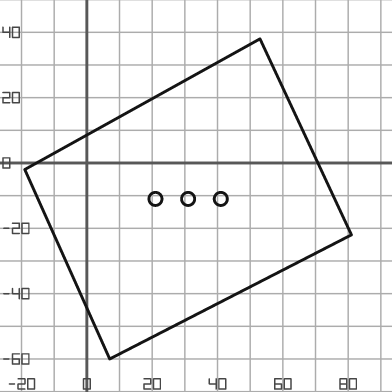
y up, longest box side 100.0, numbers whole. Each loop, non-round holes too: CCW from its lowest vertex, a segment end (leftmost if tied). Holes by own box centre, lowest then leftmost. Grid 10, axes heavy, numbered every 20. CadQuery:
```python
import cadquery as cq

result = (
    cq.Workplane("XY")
    .moveTo(7.0, -60.0)
    .lineTo(81.0, -22.0)
    .lineTo(53.0, 38.0)
    .lineTo(-19.0, -2.0)
    .close()
    .moveTo(21.0, -11.0)
    .circle(2.0)
    .moveTo(31.0, -11.0)
    .circle(2.0)
    .moveTo(41.0, -11.0)
    .circle(2.0)
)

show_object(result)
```